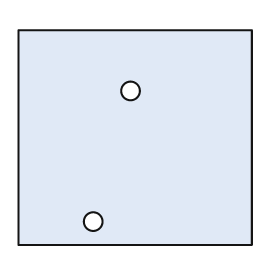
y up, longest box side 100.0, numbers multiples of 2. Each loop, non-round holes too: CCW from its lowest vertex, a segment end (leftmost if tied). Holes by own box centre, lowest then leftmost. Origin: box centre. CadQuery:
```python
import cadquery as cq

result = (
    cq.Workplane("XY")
    .moveTo(-50.0, -46.0)
    .lineTo(50.0, -46.0)
    .lineTo(50.0, 46.0)
    .lineTo(-50.0, 46.0)
    .close()
    .moveTo(-18.0, -36.0)
    .circle(4.0)
    .moveTo(-2.0, 20.0)
    .circle(4.0)
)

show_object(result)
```